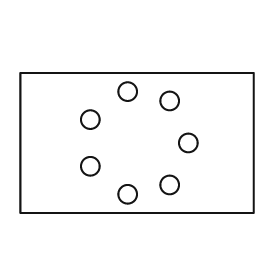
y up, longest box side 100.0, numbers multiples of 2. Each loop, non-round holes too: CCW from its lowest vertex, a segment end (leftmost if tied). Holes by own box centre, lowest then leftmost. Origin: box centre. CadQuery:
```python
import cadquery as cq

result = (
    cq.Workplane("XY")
    .moveTo(-50.0, -30.0)
    .lineTo(50.0, -30.0)
    .lineTo(50.0, 30.0)
    .lineTo(-50.0, 30.0)
    .close()
    .moveTo(-4.0, -22.0)
    .circle(4.0)
    .moveTo(14.0, -18.0)
    .circle(4.0)
    .moveTo(-20.0, -10.0)
    .circle(4.0)
    .moveTo(22.0, 0.0)
    .circle(4.0)
    .moveTo(-20.0, 10.0)
    .circle(4.0)
    .moveTo(14.0, 18.0)
    .circle(4.0)
    .moveTo(-4.0, 22.0)
    .circle(4.0)
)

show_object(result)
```